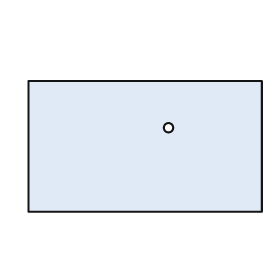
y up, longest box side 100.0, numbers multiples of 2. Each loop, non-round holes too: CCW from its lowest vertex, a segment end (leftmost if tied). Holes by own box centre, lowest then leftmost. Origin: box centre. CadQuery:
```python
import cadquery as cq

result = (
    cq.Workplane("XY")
    .moveTo(-50.0, -28.0)
    .lineTo(50.0, -28.0)
    .lineTo(50.0, 28.0)
    .lineTo(-50.0, 28.0)
    .close()
    .moveTo(10.0, 8.0)
    .circle(2.0)
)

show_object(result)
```